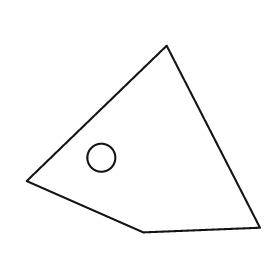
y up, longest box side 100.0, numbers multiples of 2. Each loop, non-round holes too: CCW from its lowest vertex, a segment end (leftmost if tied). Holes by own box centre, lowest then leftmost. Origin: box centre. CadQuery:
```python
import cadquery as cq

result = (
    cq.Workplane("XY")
    .moveTo(0.0, -40.0)
    .lineTo(50.0, -38.0)
    .lineTo(10.0, 40.0)
    .lineTo(-50.0, -18.0)
    .close()
    .moveTo(-18.0, -8.0)
    .circle(6.0)
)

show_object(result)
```